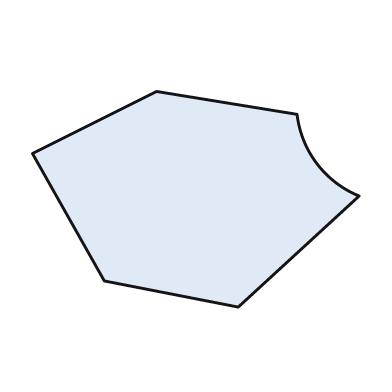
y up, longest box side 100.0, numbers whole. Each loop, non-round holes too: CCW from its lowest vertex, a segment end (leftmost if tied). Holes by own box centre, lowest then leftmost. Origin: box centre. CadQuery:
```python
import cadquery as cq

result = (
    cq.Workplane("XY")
    .moveTo(13.0, -33.0)
    .lineTo(50.0, 1.0)
    .threePointArc((37.0, 11.0), (31.0, 26.0))
    .lineTo(-12.0, 33.0)
    .lineTo(-50.0, 14.0)
    .lineTo(-28.0, -25.0)
    .close()
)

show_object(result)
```